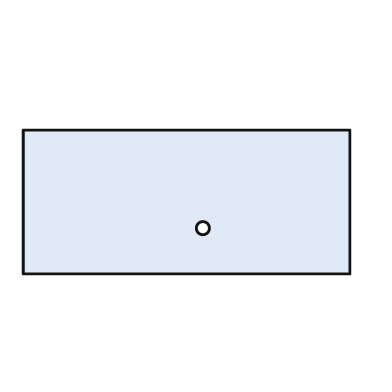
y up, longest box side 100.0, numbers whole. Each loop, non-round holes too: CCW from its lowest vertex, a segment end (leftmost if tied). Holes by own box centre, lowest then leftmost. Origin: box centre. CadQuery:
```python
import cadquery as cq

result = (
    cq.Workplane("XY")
    .moveTo(-50.0, -22.0)
    .lineTo(50.0, -22.0)
    .lineTo(50.0, 22.0)
    .lineTo(-50.0, 22.0)
    .close()
    .moveTo(5.0, -8.0)
    .circle(2.0)
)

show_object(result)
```